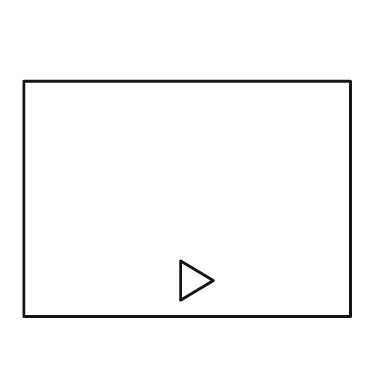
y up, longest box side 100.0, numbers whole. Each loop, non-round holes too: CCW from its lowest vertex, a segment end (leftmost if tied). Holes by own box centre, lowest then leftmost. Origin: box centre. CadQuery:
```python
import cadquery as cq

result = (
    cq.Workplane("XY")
    .moveTo(-50.0, -36.0)
    .lineTo(50.0, -36.0)
    .lineTo(50.0, 36.0)
    .lineTo(-50.0, 36.0)
    .close()
    .moveTo(-2.0, -31.0)
    .lineTo(8.0, -25.0)
    .lineTo(-2.0, -19.0)
    .close()
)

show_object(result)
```